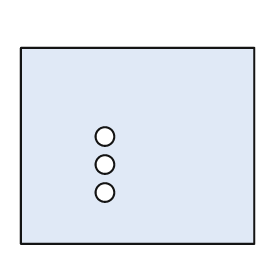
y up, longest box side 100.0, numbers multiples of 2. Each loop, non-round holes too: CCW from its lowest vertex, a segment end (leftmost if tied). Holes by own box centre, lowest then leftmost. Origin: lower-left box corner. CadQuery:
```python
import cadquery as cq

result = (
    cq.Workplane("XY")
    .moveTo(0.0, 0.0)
    .lineTo(100.0, 0.0)
    .lineTo(100.0, 84.0)
    .lineTo(0.0, 84.0)
    .close()
    .moveTo(36.0, 22.0)
    .circle(4.0)
    .moveTo(36.0, 34.0)
    .circle(4.0)
    .moveTo(36.0, 46.0)
    .circle(4.0)
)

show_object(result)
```